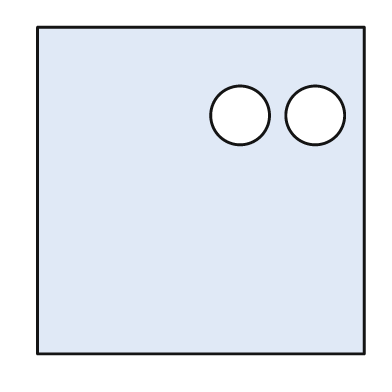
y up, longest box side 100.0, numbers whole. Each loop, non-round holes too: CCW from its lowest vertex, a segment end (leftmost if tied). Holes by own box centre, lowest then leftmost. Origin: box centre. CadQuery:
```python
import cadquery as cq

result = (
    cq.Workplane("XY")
    .moveTo(-50.0, -50.0)
    .lineTo(50.0, -50.0)
    .lineTo(50.0, 50.0)
    .lineTo(-50.0, 50.0)
    .close()
    .moveTo(12.0, 23.0)
    .circle(9.0)
    .moveTo(35.0, 23.0)
    .circle(9.0)
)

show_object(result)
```